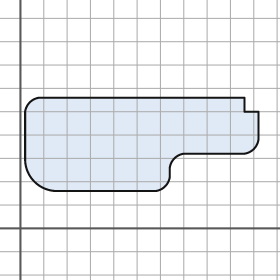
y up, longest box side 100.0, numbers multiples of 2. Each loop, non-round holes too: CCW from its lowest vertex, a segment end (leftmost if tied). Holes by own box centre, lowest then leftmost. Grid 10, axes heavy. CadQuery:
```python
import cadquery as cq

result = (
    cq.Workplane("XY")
    .moveTo(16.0, 16.0)
    .lineTo(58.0, 16.0)
    .threePointArc((62.0, 18.0), (64.0, 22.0))
    .lineTo(64.0, 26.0)
    .threePointArc((66.0, 30.0), (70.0, 32.0))
    .lineTo(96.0, 32.0)
    .threePointArc((100.0, 34.0), (102.0, 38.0))
    .lineTo(102.0, 50.0)
    .lineTo(96.0, 50.0)
    .lineTo(96.0, 56.0)
    .lineTo(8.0, 56.0)
    .threePointArc((4.0, 54.0), (2.0, 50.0))
    .lineTo(2.0, 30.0)
    .threePointArc((6.0, 20.0), (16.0, 16.0))
    .close()
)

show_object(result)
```